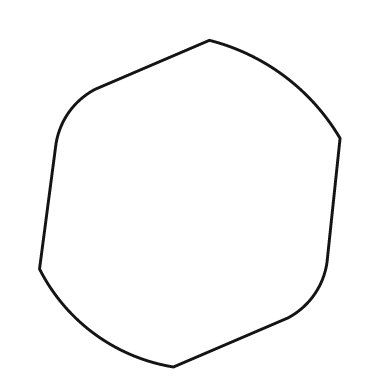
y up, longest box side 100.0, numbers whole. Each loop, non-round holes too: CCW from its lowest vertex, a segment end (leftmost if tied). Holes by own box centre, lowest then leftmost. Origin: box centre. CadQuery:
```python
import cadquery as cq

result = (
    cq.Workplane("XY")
    .moveTo(-5.0, -50.0)
    .lineTo(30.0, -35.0)
    .threePointArc((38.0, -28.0), (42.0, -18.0))
    .lineTo(46.0, 20.0)
    .threePointArc((29.0, 39.0), (6.0, 50.0))
    .lineTo(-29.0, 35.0)
    .threePointArc((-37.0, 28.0), (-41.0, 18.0))
    .lineTo(-46.0, -20.0)
    .threePointArc((-29.0, -40.0), (-5.0, -50.0))
    .close()
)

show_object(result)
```